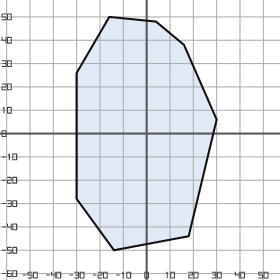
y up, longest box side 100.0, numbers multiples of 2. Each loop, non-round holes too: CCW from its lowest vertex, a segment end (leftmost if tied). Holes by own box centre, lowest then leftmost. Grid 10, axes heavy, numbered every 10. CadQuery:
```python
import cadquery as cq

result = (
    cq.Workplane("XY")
    .moveTo(-14.0, -50.0)
    .lineTo(18.0, -44.0)
    .lineTo(30.0, 6.0)
    .lineTo(16.0, 38.0)
    .lineTo(4.0, 48.0)
    .lineTo(-16.0, 50.0)
    .lineTo(-30.0, 26.0)
    .lineTo(-30.0, -28.0)
    .close()
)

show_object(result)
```